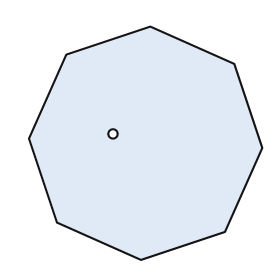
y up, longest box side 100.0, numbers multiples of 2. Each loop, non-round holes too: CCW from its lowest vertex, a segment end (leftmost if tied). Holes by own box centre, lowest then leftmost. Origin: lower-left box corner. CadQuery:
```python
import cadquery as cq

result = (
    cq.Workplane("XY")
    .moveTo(48.0, 0.0)
    .lineTo(84.0, 12.0)
    .lineTo(100.0, 48.0)
    .lineTo(88.0, 84.0)
    .lineTo(52.0, 100.0)
    .lineTo(16.0, 88.0)
    .lineTo(0.0, 52.0)
    .lineTo(12.0, 16.0)
    .close()
    .moveTo(36.0, 54.0)
    .circle(2.0)
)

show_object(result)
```